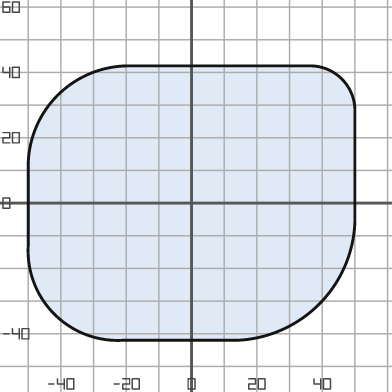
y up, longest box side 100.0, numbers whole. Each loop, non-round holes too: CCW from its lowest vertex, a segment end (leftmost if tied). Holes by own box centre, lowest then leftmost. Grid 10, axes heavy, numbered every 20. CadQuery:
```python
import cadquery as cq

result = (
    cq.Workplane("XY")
    .moveTo(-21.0, -42.0)
    .lineTo(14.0, -42.0)
    .threePointArc((39.0, -31.0), (50.0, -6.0))
    .lineTo(50.0, 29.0)
    .threePointArc((46.0, 38.0), (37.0, 42.0))
    .lineTo(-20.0, 42.0)
    .threePointArc((-41.0, 33.0), (-50.0, 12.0))
    .lineTo(-50.0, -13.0)
    .threePointArc((-42.0, -34.0), (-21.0, -42.0))
    .close()
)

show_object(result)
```